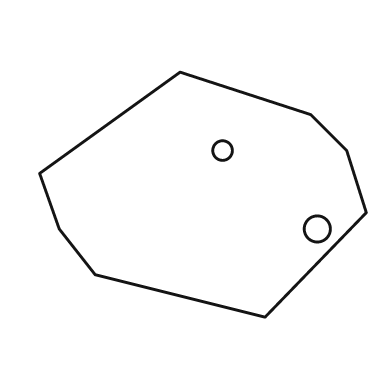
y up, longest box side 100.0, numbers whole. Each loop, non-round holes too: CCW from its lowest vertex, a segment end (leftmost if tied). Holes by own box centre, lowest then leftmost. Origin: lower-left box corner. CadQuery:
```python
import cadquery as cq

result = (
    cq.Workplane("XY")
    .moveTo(69.0, 0.0)
    .lineTo(100.0, 32.0)
    .lineTo(94.0, 51.0)
    .lineTo(83.0, 62.0)
    .lineTo(43.0, 75.0)
    .lineTo(0.0, 44.0)
    .lineTo(6.0, 27.0)
    .lineTo(17.0, 13.0)
    .close()
    .moveTo(85.0, 27.0)
    .circle(4.0)
    .moveTo(56.0, 51.0)
    .circle(3.0)
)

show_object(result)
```